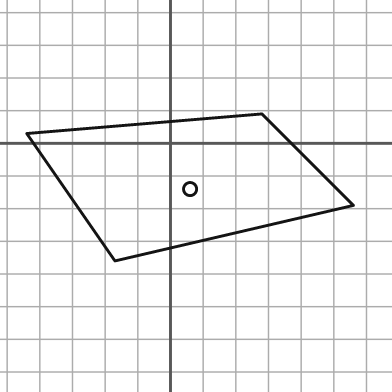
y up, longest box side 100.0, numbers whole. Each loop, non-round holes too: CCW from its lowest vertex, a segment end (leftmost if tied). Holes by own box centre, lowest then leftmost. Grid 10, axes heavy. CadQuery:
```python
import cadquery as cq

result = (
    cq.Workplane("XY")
    .moveTo(-17.0, -36.0)
    .lineTo(56.0, -19.0)
    .lineTo(28.0, 9.0)
    .lineTo(-44.0, 3.0)
    .close()
    .moveTo(6.0, -14.0)
    .circle(2.0)
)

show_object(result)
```